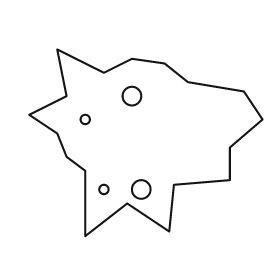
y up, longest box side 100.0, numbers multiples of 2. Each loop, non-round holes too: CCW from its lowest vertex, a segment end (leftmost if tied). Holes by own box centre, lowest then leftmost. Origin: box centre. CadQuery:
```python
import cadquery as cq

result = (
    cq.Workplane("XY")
    .moveTo(-26.0, -40.0)
    .lineTo(-8.0, -26.0)
    .lineTo(10.0, -38.0)
    .lineTo(12.0, -18.0)
    .lineTo(36.0, -16.0)
    .lineTo(36.0, -2.0)
    .lineTo(50.0, 10.0)
    .lineTo(42.0, 22.0)
    .lineTo(18.0, 26.0)
    .lineTo(8.0, 34.0)
    .lineTo(-6.0, 36.0)
    .lineTo(-18.0, 30.0)
    .lineTo(-38.0, 40.0)
    .lineTo(-34.0, 20.0)
    .lineTo(-50.0, 12.0)
    .lineTo(-38.0, 4.0)
    .lineTo(-34.0, -6.0)
    .lineTo(-26.0, -12.0)
    .close()
    .moveTo(-18.0, -20.0)
    .circle(2.0)
    .moveTo(-2.0, -20.0)
    .circle(4.0)
    .moveTo(-26.0, 10.0)
    .circle(2.0)
    .moveTo(-6.0, 20.0)
    .circle(4.0)
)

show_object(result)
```